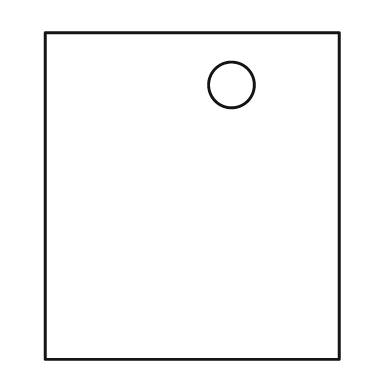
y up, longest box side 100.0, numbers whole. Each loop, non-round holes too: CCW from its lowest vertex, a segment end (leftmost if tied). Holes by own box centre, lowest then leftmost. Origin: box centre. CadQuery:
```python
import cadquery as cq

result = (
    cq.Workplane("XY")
    .moveTo(-45.0, -50.0)
    .lineTo(45.0, -50.0)
    .lineTo(45.0, 50.0)
    .lineTo(-45.0, 50.0)
    .close()
    .moveTo(12.0, 34.0)
    .circle(7.0)
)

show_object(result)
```